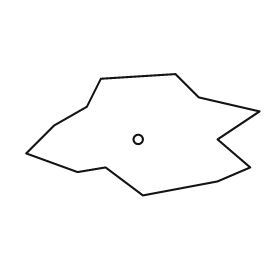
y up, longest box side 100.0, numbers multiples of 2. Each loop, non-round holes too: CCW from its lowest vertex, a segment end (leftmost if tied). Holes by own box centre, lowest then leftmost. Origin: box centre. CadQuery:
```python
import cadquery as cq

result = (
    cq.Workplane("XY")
    .moveTo(0.0, -26.0)
    .lineTo(32.0, -20.0)
    .lineTo(46.0, -14.0)
    .lineTo(32.0, -2.0)
    .lineTo(50.0, 10.0)
    .lineTo(24.0, 16.0)
    .lineTo(14.0, 26.0)
    .lineTo(-18.0, 24.0)
    .lineTo(-24.0, 12.0)
    .lineTo(-38.0, 4.0)
    .lineTo(-50.0, -8.0)
    .lineTo(-28.0, -16.0)
    .lineTo(-16.0, -14.0)
    .close()
    .moveTo(-2.0, -2.0)
    .circle(2.0)
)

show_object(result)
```